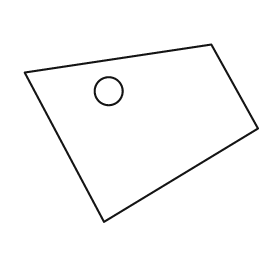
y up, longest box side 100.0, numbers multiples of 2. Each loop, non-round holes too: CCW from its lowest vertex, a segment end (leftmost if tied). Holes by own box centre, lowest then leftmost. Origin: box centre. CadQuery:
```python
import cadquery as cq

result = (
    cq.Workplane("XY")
    .moveTo(-16.0, -38.0)
    .lineTo(50.0, 2.0)
    .lineTo(30.0, 38.0)
    .lineTo(-50.0, 26.0)
    .close()
    .moveTo(-14.0, 18.0)
    .circle(6.0)
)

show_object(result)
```